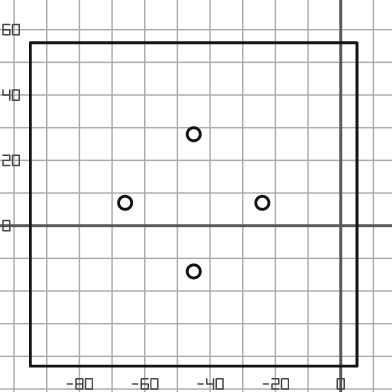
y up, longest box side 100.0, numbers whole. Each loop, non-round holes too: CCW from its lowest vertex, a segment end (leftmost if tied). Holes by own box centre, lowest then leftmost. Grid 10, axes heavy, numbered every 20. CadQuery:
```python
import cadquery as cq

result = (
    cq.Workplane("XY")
    .moveTo(-95.0, -43.0)
    .lineTo(5.0, -43.0)
    .lineTo(5.0, 56.0)
    .lineTo(-95.0, 56.0)
    .close()
    .moveTo(-45.0, -14.0)
    .circle(2.0)
    .moveTo(-66.0, 7.0)
    .circle(2.0)
    .moveTo(-24.0, 7.0)
    .circle(2.0)
    .moveTo(-45.0, 28.0)
    .circle(2.0)
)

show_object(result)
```